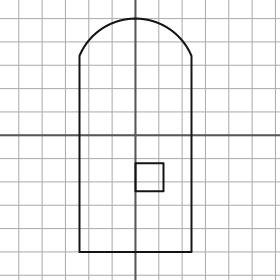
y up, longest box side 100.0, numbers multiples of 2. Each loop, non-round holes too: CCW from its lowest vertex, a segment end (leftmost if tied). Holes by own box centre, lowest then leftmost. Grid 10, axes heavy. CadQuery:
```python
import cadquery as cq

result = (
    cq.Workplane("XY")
    .moveTo(-24.0, -50.0)
    .lineTo(24.0, -50.0)
    .lineTo(24.0, 34.0)
    .threePointArc((0.0, 50.0), (-24.0, 34.0))
    .close()
    .moveTo(0.0, -24.0)
    .lineTo(12.0, -24.0)
    .lineTo(12.0, -12.0)
    .lineTo(0.0, -12.0)
    .close()
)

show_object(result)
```